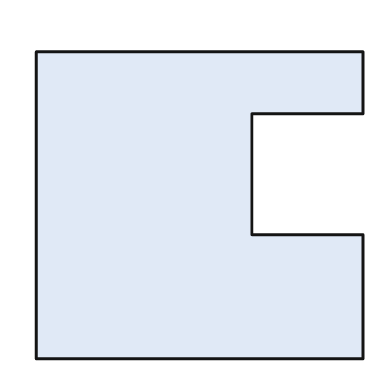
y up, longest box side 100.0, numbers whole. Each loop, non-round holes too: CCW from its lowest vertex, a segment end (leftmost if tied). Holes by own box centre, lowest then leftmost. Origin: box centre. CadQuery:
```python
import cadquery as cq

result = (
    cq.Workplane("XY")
    .moveTo(-50.0, -47.0)
    .lineTo(50.0, -47.0)
    .lineTo(50.0, -9.0)
    .lineTo(16.0, -9.0)
    .lineTo(16.0, 28.0)
    .lineTo(50.0, 28.0)
    .lineTo(50.0, 47.0)
    .lineTo(-50.0, 47.0)
    .close()
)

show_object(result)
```